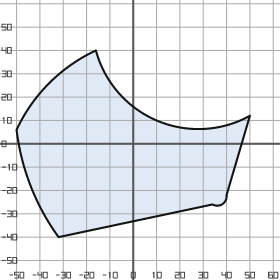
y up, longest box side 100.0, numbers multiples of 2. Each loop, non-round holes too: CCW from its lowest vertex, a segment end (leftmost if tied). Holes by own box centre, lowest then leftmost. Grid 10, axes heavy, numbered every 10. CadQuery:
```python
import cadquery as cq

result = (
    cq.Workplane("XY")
    .moveTo(-32.0, -40.0)
    .lineTo(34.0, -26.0)
    .threePointArc((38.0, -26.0), (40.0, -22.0))
    .lineTo(50.0, 12.0)
    .threePointArc((10.0, 10.0), (-16.0, 40.0))
    .threePointArc((-36.0, 26.0), (-50.0, 6.0))
    .threePointArc((-44.0, -18.0), (-32.0, -40.0))
    .close()
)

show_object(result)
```